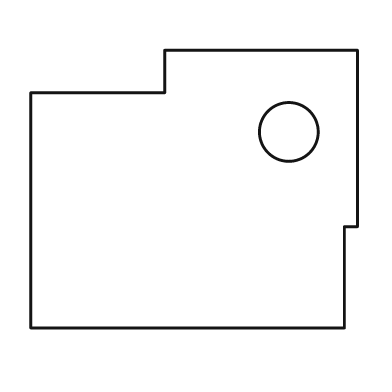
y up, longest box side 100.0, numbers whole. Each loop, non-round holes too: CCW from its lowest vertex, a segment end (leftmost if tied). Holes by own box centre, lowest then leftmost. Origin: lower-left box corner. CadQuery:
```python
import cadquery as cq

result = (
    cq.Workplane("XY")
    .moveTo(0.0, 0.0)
    .lineTo(96.0, 0.0)
    .lineTo(96.0, 31.0)
    .lineTo(100.0, 31.0)
    .lineTo(100.0, 85.0)
    .lineTo(41.0, 85.0)
    .lineTo(41.0, 72.0)
    .lineTo(0.0, 72.0)
    .close()
    .moveTo(79.0, 60.0)
    .circle(9.0)
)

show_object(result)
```